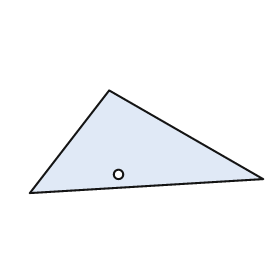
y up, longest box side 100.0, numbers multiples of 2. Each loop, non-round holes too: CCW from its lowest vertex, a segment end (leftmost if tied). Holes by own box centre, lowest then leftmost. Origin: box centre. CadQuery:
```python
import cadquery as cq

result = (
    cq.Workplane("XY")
    .moveTo(-50.0, -22.0)
    .lineTo(50.0, -16.0)
    .lineTo(-16.0, 22.0)
    .close()
    .moveTo(-12.0, -14.0)
    .circle(2.0)
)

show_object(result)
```